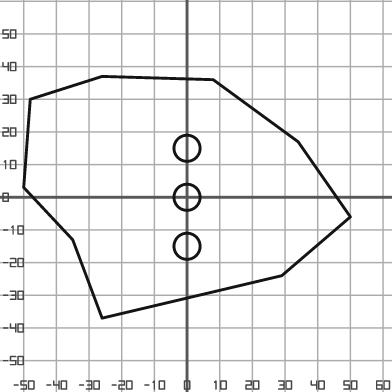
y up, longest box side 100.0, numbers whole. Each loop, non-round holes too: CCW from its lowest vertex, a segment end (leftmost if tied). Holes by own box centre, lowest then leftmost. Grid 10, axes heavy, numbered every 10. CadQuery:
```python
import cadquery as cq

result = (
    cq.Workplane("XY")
    .moveTo(-26.0, -37.0)
    .lineTo(29.0, -24.0)
    .lineTo(50.0, -6.0)
    .lineTo(34.0, 17.0)
    .lineTo(8.0, 36.0)
    .lineTo(-26.0, 37.0)
    .lineTo(-48.0, 30.0)
    .lineTo(-50.0, 3.0)
    .lineTo(-35.0, -13.0)
    .close()
    .moveTo(0.0, -15.0)
    .circle(4.0)
    .moveTo(0.0, 0.0)
    .circle(4.0)
    .moveTo(0.0, 15.0)
    .circle(4.0)
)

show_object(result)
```